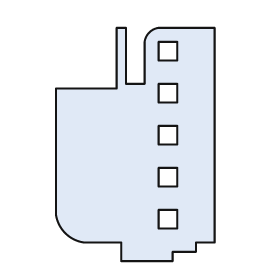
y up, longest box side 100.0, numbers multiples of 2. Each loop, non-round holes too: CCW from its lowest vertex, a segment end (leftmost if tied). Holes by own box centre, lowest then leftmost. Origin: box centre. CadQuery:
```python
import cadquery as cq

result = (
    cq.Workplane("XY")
    .moveTo(-6.0, -50.0)
    .lineTo(16.0, -50.0)
    .lineTo(16.0, -46.0)
    .lineTo(26.0, -46.0)
    .lineTo(26.0, -42.0)
    .lineTo(34.0, -42.0)
    .lineTo(34.0, 50.0)
    .lineTo(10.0, 50.0)
    .threePointArc((6.0, 48.0), (4.0, 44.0))
    .lineTo(4.0, 26.0)
    .lineTo(-4.0, 26.0)
    .lineTo(-4.0, 50.0)
    .lineTo(-8.0, 50.0)
    .lineTo(-8.0, 24.0)
    .lineTo(-34.0, 24.0)
    .lineTo(-34.0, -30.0)
    .threePointArc((-30.0, -38.0), (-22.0, -42.0))
    .lineTo(-6.0, -42.0)
    .close()
    .moveTo(10.0, -36.0)
    .lineTo(18.0, -36.0)
    .lineTo(18.0, -28.0)
    .lineTo(10.0, -28.0)
    .close()
    .moveTo(10.0, -18.0)
    .lineTo(18.0, -18.0)
    .lineTo(18.0, -10.0)
    .lineTo(10.0, -10.0)
    .close()
    .moveTo(10.0, 0.0)
    .lineTo(18.0, 0.0)
    .lineTo(18.0, 8.0)
    .lineTo(10.0, 8.0)
    .close()
    .moveTo(10.0, 18.0)
    .lineTo(18.0, 18.0)
    .lineTo(18.0, 26.0)
    .lineTo(10.0, 26.0)
    .close()
    .moveTo(10.0, 36.0)
    .lineTo(18.0, 36.0)
    .lineTo(18.0, 44.0)
    .lineTo(10.0, 44.0)
    .close()
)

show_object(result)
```